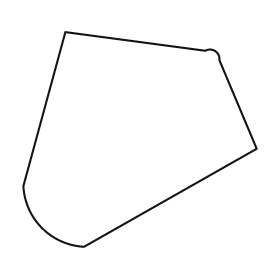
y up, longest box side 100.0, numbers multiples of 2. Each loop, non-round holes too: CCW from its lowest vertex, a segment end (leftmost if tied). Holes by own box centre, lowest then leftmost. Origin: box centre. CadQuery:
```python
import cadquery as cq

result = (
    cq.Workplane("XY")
    .moveTo(-24.0, -46.0)
    .lineTo(50.0, -4.0)
    .lineTo(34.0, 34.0)
    .threePointArc((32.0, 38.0), (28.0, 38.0))
    .lineTo(-32.0, 46.0)
    .lineTo(-50.0, -20.0)
    .threePointArc((-42.0, -38.0), (-24.0, -46.0))
    .close()
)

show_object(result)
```